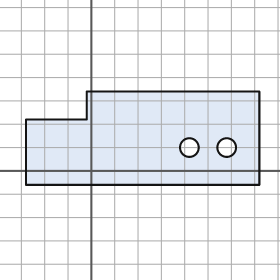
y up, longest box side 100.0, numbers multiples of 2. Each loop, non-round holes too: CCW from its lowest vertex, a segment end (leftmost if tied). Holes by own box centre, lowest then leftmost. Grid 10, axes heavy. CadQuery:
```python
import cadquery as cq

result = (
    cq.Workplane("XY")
    .moveTo(-28.0, -6.0)
    .lineTo(72.0, -6.0)
    .lineTo(72.0, 34.0)
    .lineTo(-2.0, 34.0)
    .lineTo(-2.0, 22.0)
    .lineTo(-28.0, 22.0)
    .close()
    .moveTo(42.0, 10.0)
    .circle(4.0)
    .moveTo(58.0, 10.0)
    .circle(4.0)
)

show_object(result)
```